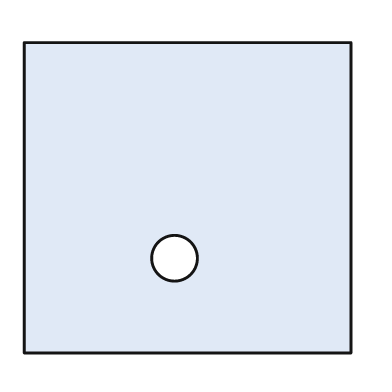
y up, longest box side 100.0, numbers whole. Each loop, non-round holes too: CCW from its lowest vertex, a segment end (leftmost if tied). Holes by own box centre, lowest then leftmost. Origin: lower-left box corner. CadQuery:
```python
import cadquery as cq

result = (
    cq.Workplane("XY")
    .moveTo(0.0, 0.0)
    .lineTo(100.0, 0.0)
    .lineTo(100.0, 95.0)
    .lineTo(0.0, 95.0)
    .close()
    .moveTo(46.0, 29.0)
    .circle(7.0)
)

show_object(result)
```